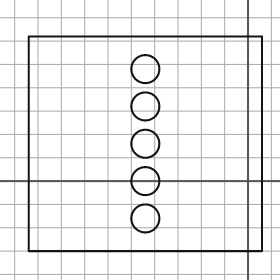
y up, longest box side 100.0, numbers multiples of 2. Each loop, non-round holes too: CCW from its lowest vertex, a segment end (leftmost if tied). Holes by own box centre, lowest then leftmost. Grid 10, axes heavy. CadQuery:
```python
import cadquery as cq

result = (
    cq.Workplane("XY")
    .moveTo(-94.0, -30.0)
    .lineTo(6.0, -30.0)
    .lineTo(6.0, 62.0)
    .lineTo(-94.0, 62.0)
    .close()
    .moveTo(-44.0, -16.0)
    .circle(6.0)
    .moveTo(-44.0, 0.0)
    .circle(6.0)
    .moveTo(-44.0, 16.0)
    .circle(6.0)
    .moveTo(-44.0, 32.0)
    .circle(6.0)
    .moveTo(-44.0, 48.0)
    .circle(6.0)
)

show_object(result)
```